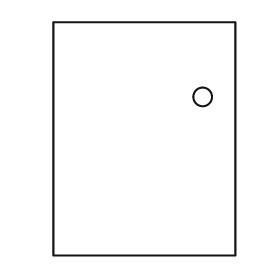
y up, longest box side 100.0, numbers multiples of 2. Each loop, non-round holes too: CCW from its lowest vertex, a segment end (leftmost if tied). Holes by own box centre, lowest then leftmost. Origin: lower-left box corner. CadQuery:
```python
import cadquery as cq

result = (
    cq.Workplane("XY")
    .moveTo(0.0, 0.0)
    .lineTo(78.0, 0.0)
    .lineTo(78.0, 100.0)
    .lineTo(0.0, 100.0)
    .close()
    .moveTo(64.0, 68.0)
    .circle(4.0)
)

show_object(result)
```